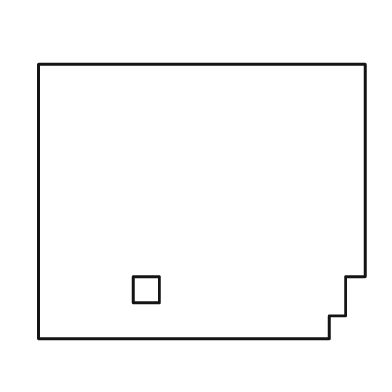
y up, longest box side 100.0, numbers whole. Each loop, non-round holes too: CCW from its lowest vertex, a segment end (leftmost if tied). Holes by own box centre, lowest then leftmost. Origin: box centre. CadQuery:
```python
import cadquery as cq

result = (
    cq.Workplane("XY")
    .moveTo(-50.0, -42.0)
    .lineTo(39.0, -42.0)
    .lineTo(39.0, -35.0)
    .lineTo(44.0, -35.0)
    .lineTo(44.0, -23.0)
    .lineTo(50.0, -23.0)
    .lineTo(50.0, 42.0)
    .lineTo(-50.0, 42.0)
    .close()
    .moveTo(-21.0, -31.0)
    .lineTo(-13.0, -31.0)
    .lineTo(-13.0, -23.0)
    .lineTo(-21.0, -23.0)
    .close()
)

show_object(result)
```